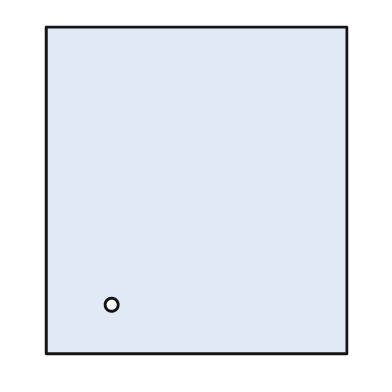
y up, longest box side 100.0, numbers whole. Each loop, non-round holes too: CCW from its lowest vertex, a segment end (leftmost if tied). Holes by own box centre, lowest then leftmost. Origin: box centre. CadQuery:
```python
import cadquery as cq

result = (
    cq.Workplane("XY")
    .moveTo(-46.0, -50.0)
    .lineTo(46.0, -50.0)
    .lineTo(46.0, 50.0)
    .lineTo(-46.0, 50.0)
    .close()
    .moveTo(-26.0, -35.0)
    .circle(2.0)
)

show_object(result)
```